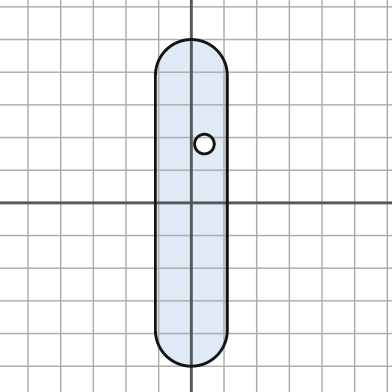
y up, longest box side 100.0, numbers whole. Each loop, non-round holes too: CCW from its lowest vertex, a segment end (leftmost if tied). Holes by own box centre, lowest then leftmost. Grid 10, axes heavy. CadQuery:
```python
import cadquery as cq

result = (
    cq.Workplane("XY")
    .moveTo(-11.0, -39.0)
    .threePointArc((0.0, -50.0), (11.0, -39.0))
    .lineTo(11.0, 39.0)
    .threePointArc((0.0, 50.0), (-11.0, 39.0))
    .close()
    .moveTo(4.0, 18.0)
    .circle(3.0)
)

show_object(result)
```